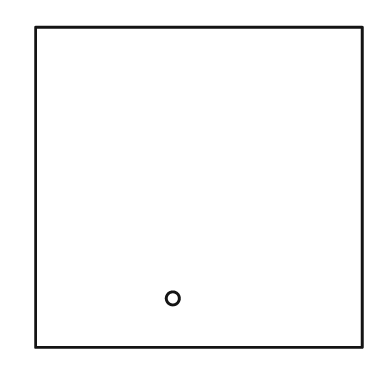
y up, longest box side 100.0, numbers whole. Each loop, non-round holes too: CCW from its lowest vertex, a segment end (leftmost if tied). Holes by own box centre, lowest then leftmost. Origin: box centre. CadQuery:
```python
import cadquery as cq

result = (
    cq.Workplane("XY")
    .moveTo(-50.0, -49.0)
    .lineTo(50.0, -49.0)
    .lineTo(50.0, 49.0)
    .lineTo(-50.0, 49.0)
    .close()
    .moveTo(-8.0, -34.0)
    .circle(2.0)
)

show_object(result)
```